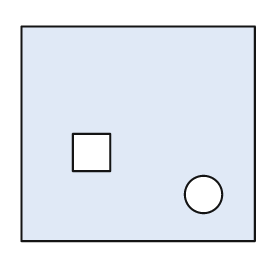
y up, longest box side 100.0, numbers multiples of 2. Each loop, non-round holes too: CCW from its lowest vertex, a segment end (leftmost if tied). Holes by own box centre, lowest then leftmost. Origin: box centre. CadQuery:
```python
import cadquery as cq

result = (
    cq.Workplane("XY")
    .moveTo(-50.0, -46.0)
    .lineTo(50.0, -46.0)
    .lineTo(50.0, 46.0)
    .lineTo(-50.0, 46.0)
    .close()
    .moveTo(28.0, -26.0)
    .circle(8.0)
    .moveTo(-28.0, -16.0)
    .lineTo(-12.0, -16.0)
    .lineTo(-12.0, 0.0)
    .lineTo(-28.0, 0.0)
    .close()
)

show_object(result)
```